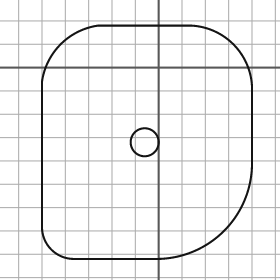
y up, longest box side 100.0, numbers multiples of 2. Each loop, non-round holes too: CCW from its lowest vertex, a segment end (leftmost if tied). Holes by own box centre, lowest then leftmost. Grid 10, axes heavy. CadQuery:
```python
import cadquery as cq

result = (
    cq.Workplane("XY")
    .moveTo(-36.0, -82.0)
    .lineTo(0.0, -82.0)
    .threePointArc((28.0, -70.0), (40.0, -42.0))
    .lineTo(40.0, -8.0)
    .threePointArc((32.0, 10.0), (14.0, 18.0))
    .lineTo(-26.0, 18.0)
    .threePointArc((-42.0, 10.0), (-50.0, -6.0))
    .lineTo(-50.0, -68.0)
    .threePointArc((-46.0, -78.0), (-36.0, -82.0))
    .close()
    .moveTo(-6.0, -32.0)
    .circle(6.0)
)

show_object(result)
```